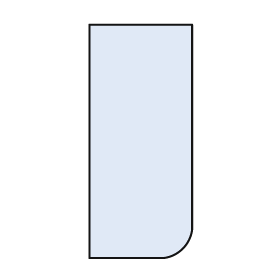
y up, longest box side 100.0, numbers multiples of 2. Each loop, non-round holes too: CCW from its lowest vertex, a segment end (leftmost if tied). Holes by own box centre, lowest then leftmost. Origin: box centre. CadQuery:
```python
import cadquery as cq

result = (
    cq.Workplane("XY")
    .moveTo(-22.0, -50.0)
    .lineTo(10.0, -50.0)
    .threePointArc((18.0, -46.0), (22.0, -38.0))
    .lineTo(22.0, 50.0)
    .lineTo(-22.0, 50.0)
    .close()
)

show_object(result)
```